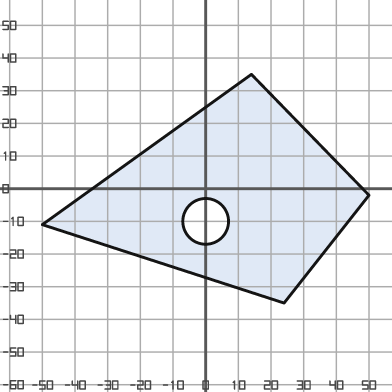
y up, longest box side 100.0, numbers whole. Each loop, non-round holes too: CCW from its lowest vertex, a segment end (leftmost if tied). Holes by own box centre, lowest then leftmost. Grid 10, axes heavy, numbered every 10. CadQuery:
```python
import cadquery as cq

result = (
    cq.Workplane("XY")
    .moveTo(24.0, -35.0)
    .lineTo(50.0, -2.0)
    .lineTo(14.0, 35.0)
    .lineTo(-50.0, -11.0)
    .close()
    .moveTo(0.0, -10.0)
    .circle(7.0)
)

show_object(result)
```